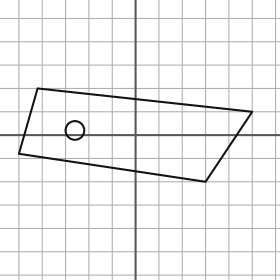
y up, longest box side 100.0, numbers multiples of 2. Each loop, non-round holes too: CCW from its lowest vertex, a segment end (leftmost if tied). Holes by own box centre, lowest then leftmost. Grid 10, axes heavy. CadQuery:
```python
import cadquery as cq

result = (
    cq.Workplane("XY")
    .moveTo(30.0, -20.0)
    .lineTo(50.0, 10.0)
    .lineTo(-42.0, 20.0)
    .lineTo(-50.0, -8.0)
    .close()
    .moveTo(-26.0, 2.0)
    .circle(4.0)
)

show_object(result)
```